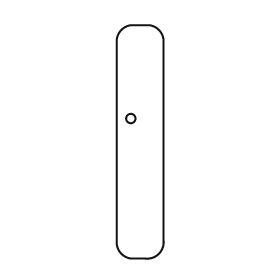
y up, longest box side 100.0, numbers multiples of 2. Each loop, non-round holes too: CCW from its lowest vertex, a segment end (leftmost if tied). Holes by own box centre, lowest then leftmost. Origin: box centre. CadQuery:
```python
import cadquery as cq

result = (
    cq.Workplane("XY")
    .moveTo(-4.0, -50.0)
    .lineTo(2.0, -50.0)
    .threePointArc((8.0, -48.0), (10.0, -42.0))
    .lineTo(10.0, 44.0)
    .threePointArc((8.0, 48.0), (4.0, 50.0))
    .lineTo(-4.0, 50.0)
    .threePointArc((-8.0, 48.0), (-10.0, 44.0))
    .lineTo(-10.0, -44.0)
    .threePointArc((-8.0, -48.0), (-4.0, -50.0))
    .close()
    .moveTo(-4.0, 10.0)
    .circle(2.0)
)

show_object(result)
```